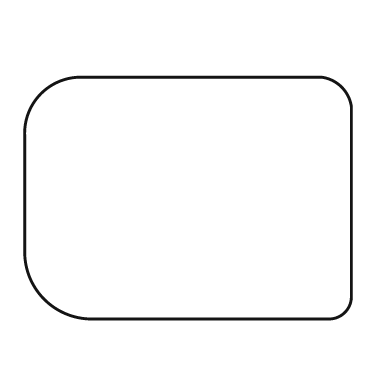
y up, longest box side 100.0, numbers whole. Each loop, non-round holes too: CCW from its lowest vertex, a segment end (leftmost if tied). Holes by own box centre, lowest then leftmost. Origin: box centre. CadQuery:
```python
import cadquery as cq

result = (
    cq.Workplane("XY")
    .moveTo(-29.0, -37.0)
    .lineTo(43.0, -37.0)
    .threePointArc((48.0, -35.0), (50.0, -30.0))
    .lineTo(50.0, 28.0)
    .threePointArc((47.0, 34.0), (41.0, 37.0))
    .lineTo(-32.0, 37.0)
    .threePointArc((-45.0, 32.0), (-50.0, 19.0))
    .lineTo(-50.0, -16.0)
    .threePointArc((-44.0, -31.0), (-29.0, -37.0))
    .close()
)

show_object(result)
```